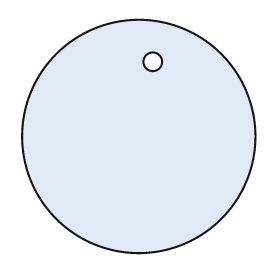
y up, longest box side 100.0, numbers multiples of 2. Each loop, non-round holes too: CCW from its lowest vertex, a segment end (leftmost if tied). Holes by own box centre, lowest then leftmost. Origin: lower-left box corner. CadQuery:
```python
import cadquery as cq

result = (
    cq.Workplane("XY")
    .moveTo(50.0, 50.0)
    .circle(50.0)
    .moveTo(56.0, 82.0)
    .circle(4.0)
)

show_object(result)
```